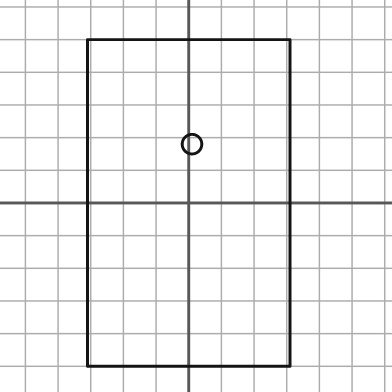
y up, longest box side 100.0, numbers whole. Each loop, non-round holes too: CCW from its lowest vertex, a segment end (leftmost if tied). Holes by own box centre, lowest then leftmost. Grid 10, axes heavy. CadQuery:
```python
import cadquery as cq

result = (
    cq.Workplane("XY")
    .moveTo(-31.0, -50.0)
    .lineTo(31.0, -50.0)
    .lineTo(31.0, 50.0)
    .lineTo(-31.0, 50.0)
    .close()
    .moveTo(1.0, 18.0)
    .circle(3.0)
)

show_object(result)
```